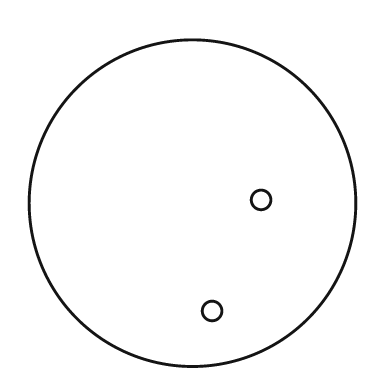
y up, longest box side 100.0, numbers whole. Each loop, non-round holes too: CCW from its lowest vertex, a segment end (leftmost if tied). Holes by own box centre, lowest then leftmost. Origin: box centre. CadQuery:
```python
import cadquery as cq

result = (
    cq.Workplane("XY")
    .moveTo(0.0, 0.0)
    .circle(50.0)
    .moveTo(6.0, -33.0)
    .circle(3.0)
    .moveTo(21.0, 1.0)
    .circle(3.0)
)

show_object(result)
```